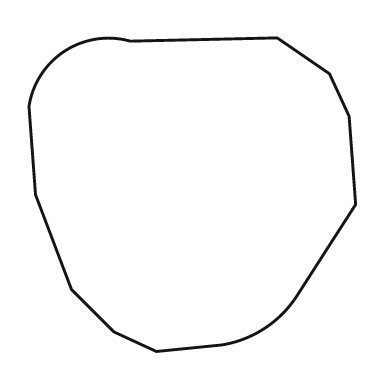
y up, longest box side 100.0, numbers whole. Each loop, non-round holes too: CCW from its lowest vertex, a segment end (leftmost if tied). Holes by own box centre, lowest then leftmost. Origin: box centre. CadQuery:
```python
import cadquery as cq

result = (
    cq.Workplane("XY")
    .moveTo(-11.0, -48.0)
    .lineTo(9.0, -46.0)
    .threePointArc((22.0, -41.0), (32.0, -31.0))
    .lineTo(50.0, -3.0)
    .lineTo(48.0, 24.0)
    .lineTo(42.0, 37.0)
    .lineTo(26.0, 48.0)
    .lineTo(-19.0, 47.0)
    .threePointArc((-39.0, 44.0), (-50.0, 27.0))
    .lineTo(-48.0, 0.0)
    .lineTo(-37.0, -29.0)
    .lineTo(-24.0, -42.0)
    .close()
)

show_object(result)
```